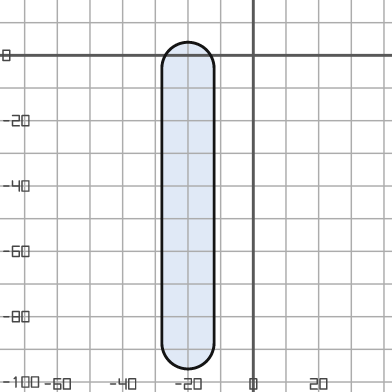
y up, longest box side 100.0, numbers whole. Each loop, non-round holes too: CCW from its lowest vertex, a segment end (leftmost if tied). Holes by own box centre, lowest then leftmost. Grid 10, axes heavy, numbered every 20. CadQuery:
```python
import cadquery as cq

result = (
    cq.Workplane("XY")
    .moveTo(-28.0, -88.0)
    .threePointArc((-20.0, -96.0), (-12.0, -88.0))
    .lineTo(-12.0, -4.0)
    .threePointArc((-20.0, 4.0), (-28.0, -4.0))
    .close()
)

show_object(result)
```